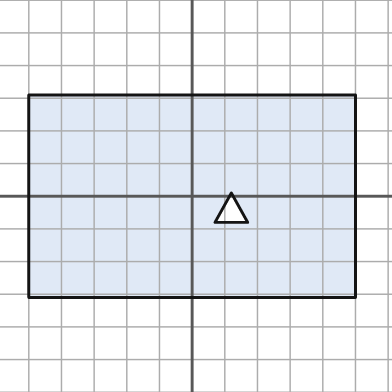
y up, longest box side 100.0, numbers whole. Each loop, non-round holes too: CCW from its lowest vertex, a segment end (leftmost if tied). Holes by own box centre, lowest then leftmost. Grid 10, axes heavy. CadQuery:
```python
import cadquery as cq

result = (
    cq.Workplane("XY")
    .moveTo(-50.0, -31.0)
    .lineTo(50.0, -31.0)
    .lineTo(50.0, 31.0)
    .lineTo(-50.0, 31.0)
    .close()
    .moveTo(7.0, -8.0)
    .lineTo(17.0, -8.0)
    .lineTo(12.0, 1.0)
    .close()
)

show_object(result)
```